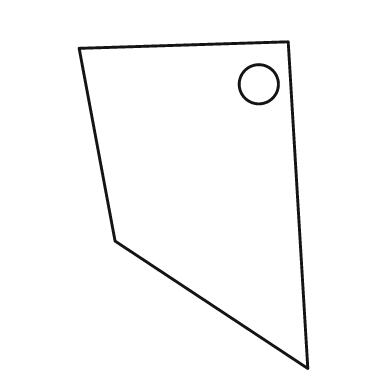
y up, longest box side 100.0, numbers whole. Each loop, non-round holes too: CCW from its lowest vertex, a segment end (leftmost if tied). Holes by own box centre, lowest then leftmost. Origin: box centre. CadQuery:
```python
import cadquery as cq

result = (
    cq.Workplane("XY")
    .moveTo(35.0, -50.0)
    .lineTo(29.0, 50.0)
    .lineTo(-35.0, 48.0)
    .lineTo(-24.0, -11.0)
    .close()
    .moveTo(20.0, 37.0)
    .circle(6.0)
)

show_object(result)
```